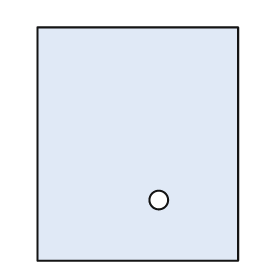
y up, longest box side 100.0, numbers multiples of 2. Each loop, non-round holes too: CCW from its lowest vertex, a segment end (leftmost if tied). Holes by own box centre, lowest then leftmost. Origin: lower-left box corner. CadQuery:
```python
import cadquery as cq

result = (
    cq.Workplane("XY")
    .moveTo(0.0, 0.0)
    .lineTo(86.0, 0.0)
    .lineTo(86.0, 100.0)
    .lineTo(0.0, 100.0)
    .close()
    .moveTo(52.0, 26.0)
    .circle(4.0)
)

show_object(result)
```